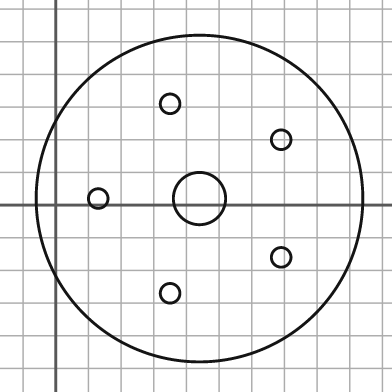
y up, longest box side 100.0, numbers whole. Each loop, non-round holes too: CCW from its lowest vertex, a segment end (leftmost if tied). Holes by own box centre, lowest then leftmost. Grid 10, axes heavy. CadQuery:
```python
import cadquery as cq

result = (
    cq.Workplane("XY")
    .moveTo(44.0, 2.0)
    .circle(50.0)
    .moveTo(35.0, -27.0)
    .circle(3.0)
    .moveTo(69.0, -16.0)
    .circle(3.0)
    .moveTo(13.0, 2.0)
    .circle(3.0)
    .moveTo(44.0, 2.0)
    .circle(8.0)
    .moveTo(69.0, 20.0)
    .circle(3.0)
    .moveTo(35.0, 31.0)
    .circle(3.0)
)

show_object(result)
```